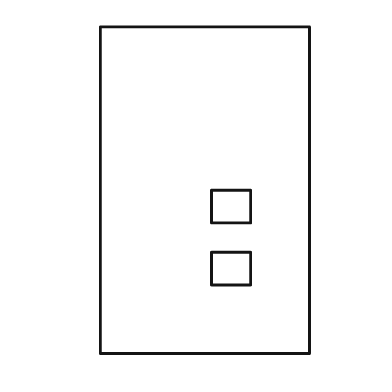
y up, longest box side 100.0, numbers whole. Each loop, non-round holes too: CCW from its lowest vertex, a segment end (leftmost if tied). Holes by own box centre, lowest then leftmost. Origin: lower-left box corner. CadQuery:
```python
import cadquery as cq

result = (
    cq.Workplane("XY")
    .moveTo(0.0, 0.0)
    .lineTo(64.0, 0.0)
    .lineTo(64.0, 100.0)
    .lineTo(0.0, 100.0)
    .close()
    .moveTo(34.0, 21.0)
    .lineTo(46.0, 21.0)
    .lineTo(46.0, 31.0)
    .lineTo(34.0, 31.0)
    .close()
    .moveTo(34.0, 40.0)
    .lineTo(46.0, 40.0)
    .lineTo(46.0, 50.0)
    .lineTo(34.0, 50.0)
    .close()
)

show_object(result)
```